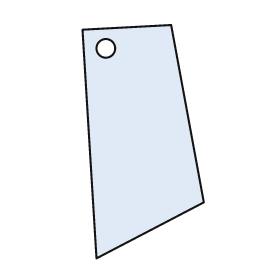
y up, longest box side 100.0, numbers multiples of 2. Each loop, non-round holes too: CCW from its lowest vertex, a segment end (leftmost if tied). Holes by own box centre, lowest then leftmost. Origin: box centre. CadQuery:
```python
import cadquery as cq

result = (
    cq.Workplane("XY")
    .moveTo(-20.0, -50.0)
    .lineTo(26.0, -26.0)
    .lineTo(12.0, 50.0)
    .lineTo(-26.0, 48.0)
    .close()
    .moveTo(-16.0, 40.0)
    .circle(4.0)
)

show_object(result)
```